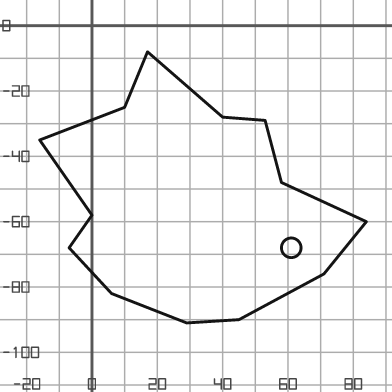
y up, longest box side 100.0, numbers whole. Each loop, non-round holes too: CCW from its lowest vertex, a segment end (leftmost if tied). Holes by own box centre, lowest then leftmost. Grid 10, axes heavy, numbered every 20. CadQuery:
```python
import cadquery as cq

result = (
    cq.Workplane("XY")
    .moveTo(29.0, -91.0)
    .lineTo(45.0, -90.0)
    .lineTo(71.0, -76.0)
    .lineTo(84.0, -60.0)
    .lineTo(58.0, -48.0)
    .lineTo(53.0, -29.0)
    .lineTo(40.0, -28.0)
    .lineTo(17.0, -8.0)
    .lineTo(10.0, -25.0)
    .lineTo(-16.0, -35.0)
    .lineTo(0.0, -58.0)
    .lineTo(-7.0, -68.0)
    .lineTo(6.0, -82.0)
    .close()
    .moveTo(61.0, -68.0)
    .circle(3.0)
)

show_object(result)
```